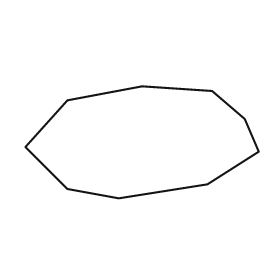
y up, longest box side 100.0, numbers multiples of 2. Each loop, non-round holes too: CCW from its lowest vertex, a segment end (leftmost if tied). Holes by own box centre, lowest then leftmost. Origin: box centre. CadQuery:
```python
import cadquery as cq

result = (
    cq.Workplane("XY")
    .moveTo(-10.0, -24.0)
    .lineTo(28.0, -18.0)
    .lineTo(50.0, -4.0)
    .lineTo(44.0, 10.0)
    .lineTo(30.0, 22.0)
    .lineTo(0.0, 24.0)
    .lineTo(-32.0, 18.0)
    .lineTo(-50.0, -2.0)
    .lineTo(-32.0, -20.0)
    .close()
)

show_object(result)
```